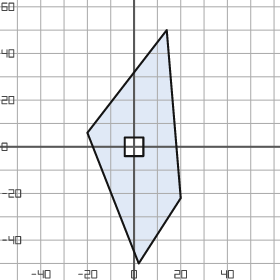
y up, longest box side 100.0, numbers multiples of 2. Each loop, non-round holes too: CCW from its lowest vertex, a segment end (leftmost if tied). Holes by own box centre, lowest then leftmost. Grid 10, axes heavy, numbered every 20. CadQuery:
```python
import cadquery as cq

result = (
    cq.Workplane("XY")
    .moveTo(2.0, -50.0)
    .lineTo(20.0, -22.0)
    .lineTo(14.0, 50.0)
    .lineTo(-20.0, 6.0)
    .close()
    .moveTo(-4.0, -4.0)
    .lineTo(4.0, -4.0)
    .lineTo(4.0, 4.0)
    .lineTo(-4.0, 4.0)
    .close()
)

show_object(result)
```